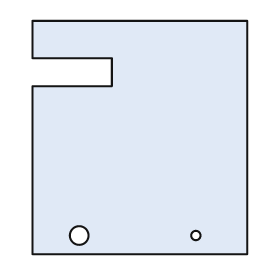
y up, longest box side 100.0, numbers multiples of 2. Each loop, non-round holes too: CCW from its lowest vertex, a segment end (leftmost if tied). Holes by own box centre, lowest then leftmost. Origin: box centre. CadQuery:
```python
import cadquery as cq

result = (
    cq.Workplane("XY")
    .moveTo(-46.0, -50.0)
    .lineTo(46.0, -50.0)
    .lineTo(46.0, 50.0)
    .lineTo(-46.0, 50.0)
    .lineTo(-46.0, 34.0)
    .lineTo(-12.0, 34.0)
    .lineTo(-12.0, 22.0)
    .lineTo(-46.0, 22.0)
    .close()
    .moveTo(-26.0, -42.0)
    .circle(4.0)
    .moveTo(24.0, -42.0)
    .circle(2.0)
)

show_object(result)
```